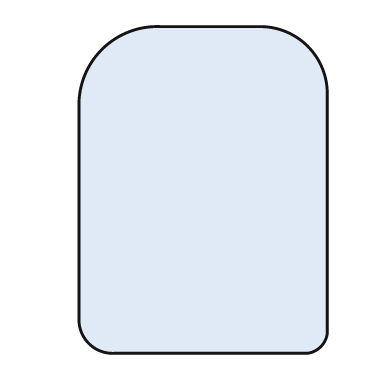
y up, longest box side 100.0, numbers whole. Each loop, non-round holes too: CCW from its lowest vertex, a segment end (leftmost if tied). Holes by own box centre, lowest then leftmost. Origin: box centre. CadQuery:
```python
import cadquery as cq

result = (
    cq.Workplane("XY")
    .moveTo(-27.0, -50.0)
    .lineTo(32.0, -50.0)
    .threePointArc((36.0, -48.0), (38.0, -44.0))
    .lineTo(38.0, 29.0)
    .threePointArc((32.0, 44.0), (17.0, 50.0))
    .lineTo(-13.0, 50.0)
    .threePointArc((-31.0, 43.0), (-38.0, 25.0))
    .lineTo(-38.0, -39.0)
    .threePointArc((-35.0, -47.0), (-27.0, -50.0))
    .close()
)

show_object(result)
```